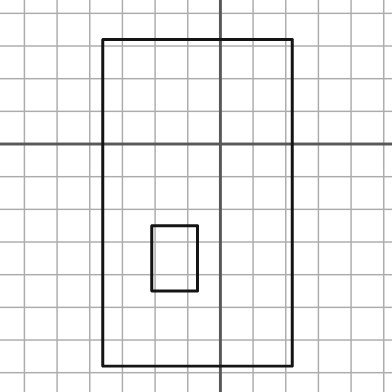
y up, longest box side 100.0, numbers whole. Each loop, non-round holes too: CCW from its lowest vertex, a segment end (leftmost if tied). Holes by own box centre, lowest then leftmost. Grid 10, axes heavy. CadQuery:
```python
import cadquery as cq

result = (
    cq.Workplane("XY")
    .moveTo(-36.0, -68.0)
    .lineTo(22.0, -68.0)
    .lineTo(22.0, 32.0)
    .lineTo(-36.0, 32.0)
    .close()
    .moveTo(-21.0, -45.0)
    .lineTo(-7.0, -45.0)
    .lineTo(-7.0, -25.0)
    .lineTo(-21.0, -25.0)
    .close()
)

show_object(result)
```